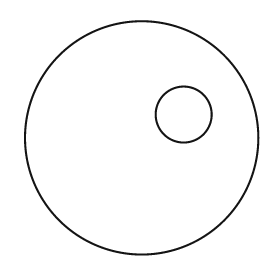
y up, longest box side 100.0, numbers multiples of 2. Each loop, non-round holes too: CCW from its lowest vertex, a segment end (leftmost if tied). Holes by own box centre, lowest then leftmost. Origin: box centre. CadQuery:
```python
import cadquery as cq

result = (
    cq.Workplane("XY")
    .moveTo(0.0, 0.0)
    .circle(50.0)
    .moveTo(18.0, 10.0)
    .circle(12.0)
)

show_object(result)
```